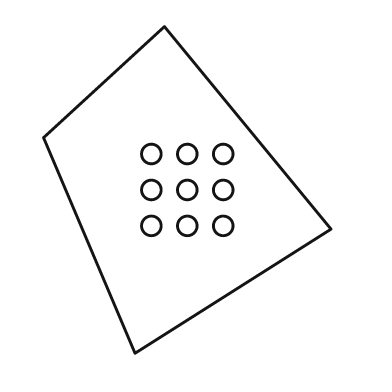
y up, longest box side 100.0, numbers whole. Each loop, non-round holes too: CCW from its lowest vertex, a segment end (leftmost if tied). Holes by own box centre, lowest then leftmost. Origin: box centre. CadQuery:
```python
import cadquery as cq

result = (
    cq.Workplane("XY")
    .moveTo(-16.0, -50.0)
    .lineTo(44.0, -12.0)
    .lineTo(-7.0, 50.0)
    .lineTo(-44.0, 16.0)
    .close()
    .moveTo(-11.0, -11.0)
    .circle(3.0)
    .moveTo(0.0, -11.0)
    .circle(3.0)
    .moveTo(11.0, -11.0)
    .circle(3.0)
    .moveTo(-11.0, 0.0)
    .circle(3.0)
    .moveTo(0.0, 0.0)
    .circle(3.0)
    .moveTo(11.0, 0.0)
    .circle(3.0)
    .moveTo(-11.0, 11.0)
    .circle(3.0)
    .moveTo(0.0, 11.0)
    .circle(3.0)
    .moveTo(11.0, 11.0)
    .circle(3.0)
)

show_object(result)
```